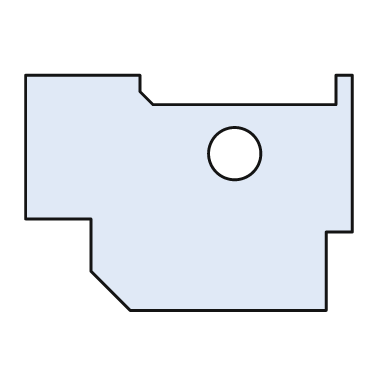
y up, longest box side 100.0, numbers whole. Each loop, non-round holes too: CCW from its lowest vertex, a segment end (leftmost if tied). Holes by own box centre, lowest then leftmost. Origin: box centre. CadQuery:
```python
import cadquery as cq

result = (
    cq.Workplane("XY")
    .moveTo(-18.0, -36.0)
    .lineTo(42.0, -36.0)
    .lineTo(42.0, -12.0)
    .lineTo(50.0, -12.0)
    .lineTo(50.0, 36.0)
    .lineTo(45.0, 36.0)
    .lineTo(45.0, 27.0)
    .lineTo(-11.0, 27.0)
    .lineTo(-15.0, 31.0)
    .lineTo(-15.0, 36.0)
    .lineTo(-50.0, 36.0)
    .lineTo(-50.0, -8.0)
    .lineTo(-30.0, -8.0)
    .lineTo(-30.0, -24.0)
    .close()
    .moveTo(14.0, 12.0)
    .circle(8.0)
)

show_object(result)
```